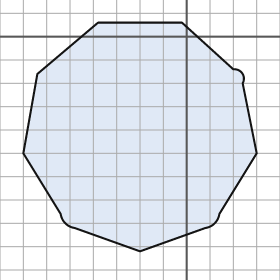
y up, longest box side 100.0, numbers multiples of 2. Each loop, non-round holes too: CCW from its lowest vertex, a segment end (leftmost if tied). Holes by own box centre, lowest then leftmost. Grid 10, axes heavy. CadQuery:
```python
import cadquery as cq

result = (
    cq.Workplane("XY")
    .moveTo(-20.0, -92.0)
    .lineTo(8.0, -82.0)
    .threePointArc((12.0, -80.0), (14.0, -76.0))
    .lineTo(30.0, -50.0)
    .lineTo(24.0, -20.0)
    .threePointArc((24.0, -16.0), (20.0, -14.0))
    .lineTo(-2.0, 6.0)
    .lineTo(-38.0, 6.0)
    .lineTo(-64.0, -16.0)
    .lineTo(-70.0, -50.0)
    .lineTo(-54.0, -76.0)
    .threePointArc((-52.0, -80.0), (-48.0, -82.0))
    .close()
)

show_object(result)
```